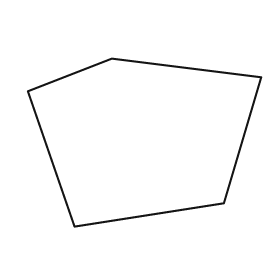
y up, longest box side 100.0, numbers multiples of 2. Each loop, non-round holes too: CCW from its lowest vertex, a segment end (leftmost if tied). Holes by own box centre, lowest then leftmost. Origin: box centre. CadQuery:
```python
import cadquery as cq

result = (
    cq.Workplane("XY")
    .moveTo(-30.0, -36.0)
    .lineTo(34.0, -26.0)
    .lineTo(50.0, 28.0)
    .lineTo(-14.0, 36.0)
    .lineTo(-50.0, 22.0)
    .close()
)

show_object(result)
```